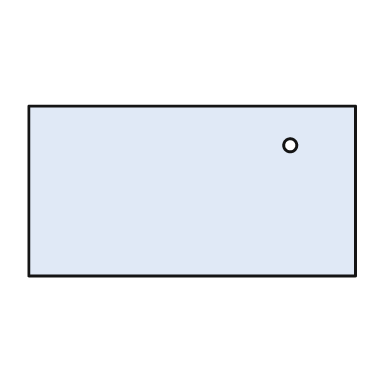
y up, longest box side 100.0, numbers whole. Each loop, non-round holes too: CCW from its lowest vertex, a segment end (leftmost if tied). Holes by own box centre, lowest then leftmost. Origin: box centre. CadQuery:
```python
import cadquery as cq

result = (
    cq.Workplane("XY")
    .moveTo(-50.0, -26.0)
    .lineTo(50.0, -26.0)
    .lineTo(50.0, 26.0)
    .lineTo(-50.0, 26.0)
    .close()
    .moveTo(30.0, 14.0)
    .circle(2.0)
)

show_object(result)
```